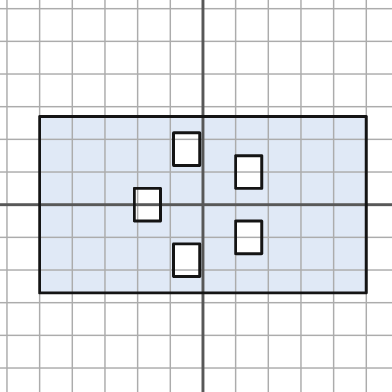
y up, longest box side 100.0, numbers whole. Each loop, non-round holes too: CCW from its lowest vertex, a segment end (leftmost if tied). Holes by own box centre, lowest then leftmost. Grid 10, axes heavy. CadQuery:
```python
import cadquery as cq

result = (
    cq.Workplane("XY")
    .moveTo(-50.0, -27.0)
    .lineTo(50.0, -27.0)
    .lineTo(50.0, 27.0)
    .lineTo(-50.0, 27.0)
    .close()
    .moveTo(-9.0, -22.0)
    .lineTo(-1.0, -22.0)
    .lineTo(-1.0, -12.0)
    .lineTo(-9.0, -12.0)
    .close()
    .moveTo(10.0, -15.0)
    .lineTo(18.0, -15.0)
    .lineTo(18.0, -5.0)
    .lineTo(10.0, -5.0)
    .close()
    .moveTo(-21.0, -5.0)
    .lineTo(-13.0, -5.0)
    .lineTo(-13.0, 5.0)
    .lineTo(-21.0, 5.0)
    .close()
    .moveTo(10.0, 5.0)
    .lineTo(18.0, 5.0)
    .lineTo(18.0, 15.0)
    .lineTo(10.0, 15.0)
    .close()
    .moveTo(-9.0, 12.0)
    .lineTo(-1.0, 12.0)
    .lineTo(-1.0, 22.0)
    .lineTo(-9.0, 22.0)
    .close()
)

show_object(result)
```